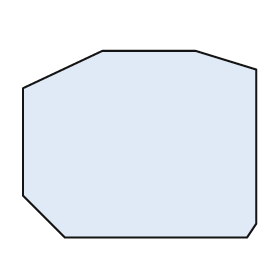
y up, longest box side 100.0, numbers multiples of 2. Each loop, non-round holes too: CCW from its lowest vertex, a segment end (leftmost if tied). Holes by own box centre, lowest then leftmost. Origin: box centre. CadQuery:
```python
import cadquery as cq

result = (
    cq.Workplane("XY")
    .moveTo(-32.0, -40.0)
    .lineTo(46.0, -40.0)
    .lineTo(50.0, -34.0)
    .lineTo(50.0, 32.0)
    .lineTo(24.0, 40.0)
    .lineTo(-16.0, 40.0)
    .lineTo(-50.0, 24.0)
    .lineTo(-50.0, -22.0)
    .close()
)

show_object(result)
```